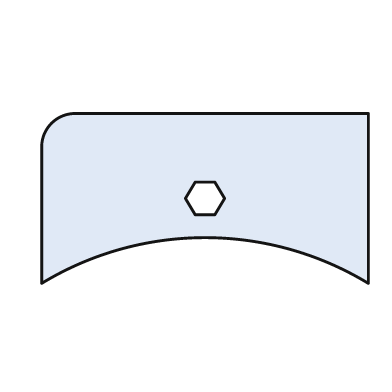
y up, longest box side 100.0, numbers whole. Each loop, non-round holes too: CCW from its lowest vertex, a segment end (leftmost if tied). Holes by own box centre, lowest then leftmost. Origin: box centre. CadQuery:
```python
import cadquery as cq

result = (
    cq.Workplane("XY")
    .moveTo(-50.0, -26.0)
    .threePointArc((0.0, -12.0), (50.0, -26.0))
    .lineTo(50.0, 26.0)
    .lineTo(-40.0, 26.0)
    .threePointArc((-47.0, 23.0), (-50.0, 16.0))
    .close()
    .moveTo(-3.0, -5.0)
    .lineTo(3.0, -5.0)
    .lineTo(6.0, 0.0)
    .lineTo(3.0, 5.0)
    .lineTo(-3.0, 5.0)
    .lineTo(-6.0, 0.0)
    .close()
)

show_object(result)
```